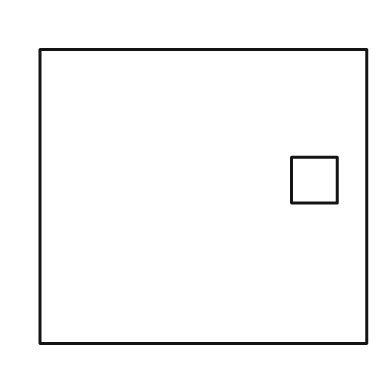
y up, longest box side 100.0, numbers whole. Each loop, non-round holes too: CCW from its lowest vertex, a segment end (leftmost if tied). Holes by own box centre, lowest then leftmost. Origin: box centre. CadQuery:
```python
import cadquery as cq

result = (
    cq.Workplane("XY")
    .moveTo(-50.0, -45.0)
    .lineTo(50.0, -45.0)
    .lineTo(50.0, 45.0)
    .lineTo(-50.0, 45.0)
    .close()
    .moveTo(27.0, -2.0)
    .lineTo(41.0, -2.0)
    .lineTo(41.0, 12.0)
    .lineTo(27.0, 12.0)
    .close()
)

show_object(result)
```